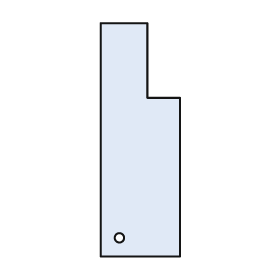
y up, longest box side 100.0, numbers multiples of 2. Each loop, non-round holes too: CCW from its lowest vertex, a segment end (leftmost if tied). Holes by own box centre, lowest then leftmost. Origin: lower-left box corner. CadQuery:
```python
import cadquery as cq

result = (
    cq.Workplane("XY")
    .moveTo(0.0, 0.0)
    .lineTo(34.0, 0.0)
    .lineTo(34.0, 68.0)
    .lineTo(20.0, 68.0)
    .lineTo(20.0, 100.0)
    .lineTo(0.0, 100.0)
    .close()
    .moveTo(8.0, 8.0)
    .circle(2.0)
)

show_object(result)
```